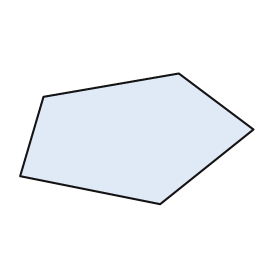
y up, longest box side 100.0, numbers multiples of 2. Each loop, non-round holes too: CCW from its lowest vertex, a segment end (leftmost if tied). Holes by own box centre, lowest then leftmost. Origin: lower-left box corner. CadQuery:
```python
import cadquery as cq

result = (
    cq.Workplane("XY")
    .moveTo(60.0, 0.0)
    .lineTo(100.0, 32.0)
    .lineTo(68.0, 56.0)
    .lineTo(10.0, 46.0)
    .lineTo(0.0, 12.0)
    .close()
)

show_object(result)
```